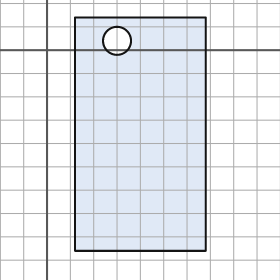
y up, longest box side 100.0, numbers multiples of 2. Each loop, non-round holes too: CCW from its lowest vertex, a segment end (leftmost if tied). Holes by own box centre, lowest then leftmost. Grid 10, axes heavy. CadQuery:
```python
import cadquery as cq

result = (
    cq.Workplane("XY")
    .moveTo(12.0, -86.0)
    .lineTo(68.0, -86.0)
    .lineTo(68.0, 14.0)
    .lineTo(12.0, 14.0)
    .close()
    .moveTo(30.0, 4.0)
    .circle(6.0)
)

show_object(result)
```